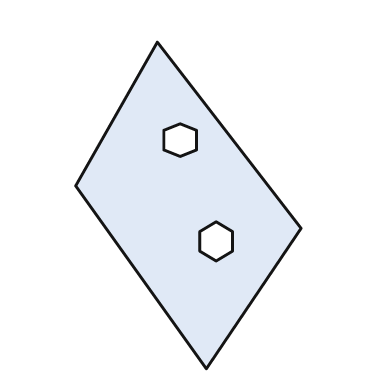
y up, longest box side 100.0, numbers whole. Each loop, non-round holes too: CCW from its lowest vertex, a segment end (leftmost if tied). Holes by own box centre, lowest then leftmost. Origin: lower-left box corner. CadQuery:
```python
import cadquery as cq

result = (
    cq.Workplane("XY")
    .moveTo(40.0, 0.0)
    .lineTo(69.0, 43.0)
    .lineTo(25.0, 100.0)
    .lineTo(0.0, 56.0)
    .close()
    .moveTo(43.0, 33.0)
    .lineTo(48.0, 36.0)
    .lineTo(48.0, 42.0)
    .lineTo(43.0, 45.0)
    .lineTo(38.0, 42.0)
    .lineTo(38.0, 36.0)
    .close()
    .moveTo(32.0, 65.0)
    .lineTo(37.0, 67.0)
    .lineTo(37.0, 73.0)
    .lineTo(32.0, 75.0)
    .lineTo(27.0, 73.0)
    .lineTo(27.0, 67.0)
    .close()
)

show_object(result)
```